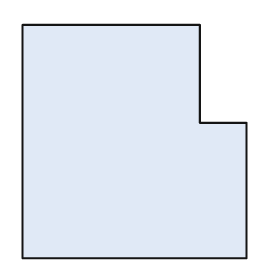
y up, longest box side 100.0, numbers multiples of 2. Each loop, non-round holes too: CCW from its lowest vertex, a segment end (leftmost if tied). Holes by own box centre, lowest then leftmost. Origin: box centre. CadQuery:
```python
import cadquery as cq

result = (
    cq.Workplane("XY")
    .moveTo(-48.0, -50.0)
    .lineTo(48.0, -50.0)
    .lineTo(48.0, 8.0)
    .lineTo(28.0, 8.0)
    .lineTo(28.0, 50.0)
    .lineTo(-48.0, 50.0)
    .close()
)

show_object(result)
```